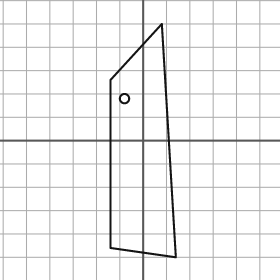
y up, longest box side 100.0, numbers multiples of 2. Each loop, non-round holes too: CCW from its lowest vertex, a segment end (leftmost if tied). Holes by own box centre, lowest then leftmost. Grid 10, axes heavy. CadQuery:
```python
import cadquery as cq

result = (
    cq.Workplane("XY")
    .moveTo(14.0, -50.0)
    .lineTo(8.0, 50.0)
    .lineTo(-14.0, 26.0)
    .lineTo(-14.0, -46.0)
    .close()
    .moveTo(-8.0, 18.0)
    .circle(2.0)
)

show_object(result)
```